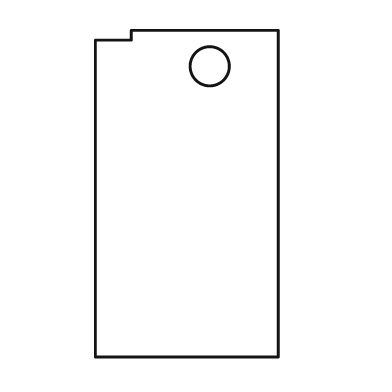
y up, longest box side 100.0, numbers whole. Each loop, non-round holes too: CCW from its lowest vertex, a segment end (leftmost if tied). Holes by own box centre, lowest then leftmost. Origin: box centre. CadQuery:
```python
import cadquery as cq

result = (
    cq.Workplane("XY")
    .moveTo(-28.0, -50.0)
    .lineTo(28.0, -50.0)
    .lineTo(28.0, 50.0)
    .lineTo(-17.0, 50.0)
    .lineTo(-17.0, 47.0)
    .lineTo(-28.0, 47.0)
    .close()
    .moveTo(7.0, 39.0)
    .circle(6.0)
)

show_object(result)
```